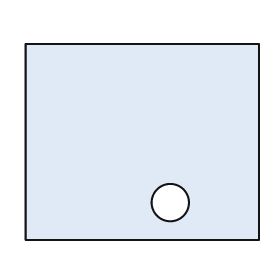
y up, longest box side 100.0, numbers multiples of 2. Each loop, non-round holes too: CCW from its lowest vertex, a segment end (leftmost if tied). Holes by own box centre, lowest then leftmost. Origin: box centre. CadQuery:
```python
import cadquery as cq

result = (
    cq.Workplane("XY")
    .moveTo(-50.0, -42.0)
    .lineTo(50.0, -42.0)
    .lineTo(50.0, 42.0)
    .lineTo(-50.0, 42.0)
    .close()
    .moveTo(12.0, -26.0)
    .circle(8.0)
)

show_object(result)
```